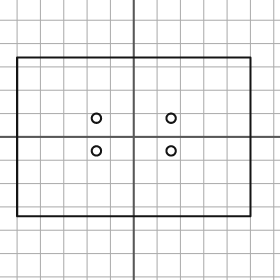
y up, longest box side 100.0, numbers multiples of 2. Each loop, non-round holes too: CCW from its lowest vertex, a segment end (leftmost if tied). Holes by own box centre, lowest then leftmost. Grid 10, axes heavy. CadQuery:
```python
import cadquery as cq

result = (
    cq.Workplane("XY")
    .moveTo(-50.0, -34.0)
    .lineTo(50.0, -34.0)
    .lineTo(50.0, 34.0)
    .lineTo(-50.0, 34.0)
    .close()
    .moveTo(-16.0, -6.0)
    .circle(2.0)
    .moveTo(16.0, -6.0)
    .circle(2.0)
    .moveTo(-16.0, 8.0)
    .circle(2.0)
    .moveTo(16.0, 8.0)
    .circle(2.0)
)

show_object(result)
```